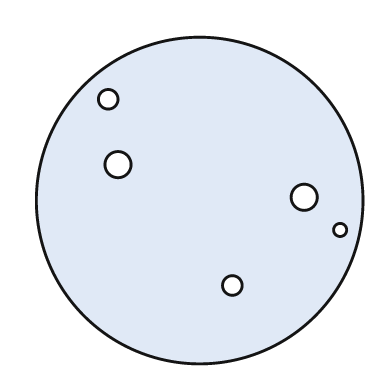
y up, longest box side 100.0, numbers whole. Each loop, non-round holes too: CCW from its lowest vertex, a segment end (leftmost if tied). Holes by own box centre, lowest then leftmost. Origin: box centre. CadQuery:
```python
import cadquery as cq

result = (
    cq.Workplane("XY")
    .moveTo(0.0, 0.0)
    .circle(50.0)
    .moveTo(10.0, -26.0)
    .circle(3.0)
    .moveTo(43.0, -9.0)
    .circle(2.0)
    .moveTo(32.0, 1.0)
    .circle(4.0)
    .moveTo(-25.0, 11.0)
    .circle(4.0)
    .moveTo(-28.0, 31.0)
    .circle(3.0)
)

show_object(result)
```